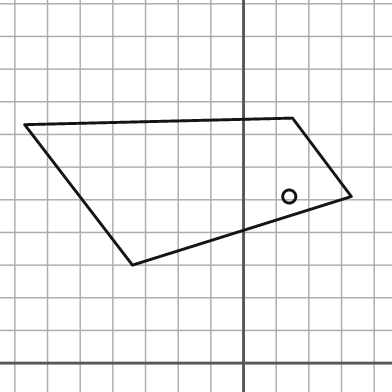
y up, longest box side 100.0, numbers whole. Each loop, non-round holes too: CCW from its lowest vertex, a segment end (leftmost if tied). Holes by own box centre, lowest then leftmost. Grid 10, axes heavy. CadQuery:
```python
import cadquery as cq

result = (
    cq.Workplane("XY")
    .moveTo(-34.0, 30.0)
    .lineTo(33.0, 51.0)
    .lineTo(15.0, 75.0)
    .lineTo(-67.0, 73.0)
    .close()
    .moveTo(14.0, 51.0)
    .circle(2.0)
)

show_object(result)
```